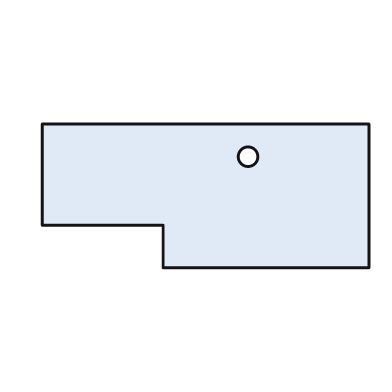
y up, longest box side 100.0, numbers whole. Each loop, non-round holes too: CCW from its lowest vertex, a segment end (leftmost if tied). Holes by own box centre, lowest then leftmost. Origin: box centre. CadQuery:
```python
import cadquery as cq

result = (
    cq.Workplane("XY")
    .moveTo(-13.0, -22.0)
    .lineTo(50.0, -22.0)
    .lineTo(50.0, 22.0)
    .lineTo(-50.0, 22.0)
    .lineTo(-50.0, -9.0)
    .lineTo(-13.0, -9.0)
    .close()
    .moveTo(13.0, 12.0)
    .circle(3.0)
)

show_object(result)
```